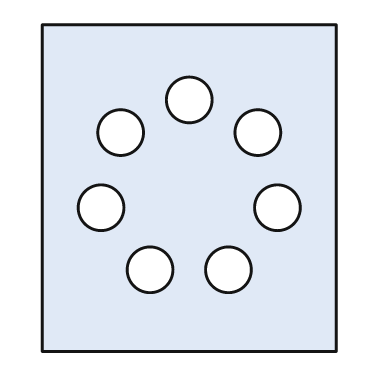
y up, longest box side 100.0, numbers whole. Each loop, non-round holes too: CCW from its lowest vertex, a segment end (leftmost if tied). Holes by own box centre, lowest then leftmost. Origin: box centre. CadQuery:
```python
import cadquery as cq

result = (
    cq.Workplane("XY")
    .moveTo(-45.0, -50.0)
    .lineTo(45.0, -50.0)
    .lineTo(45.0, 50.0)
    .lineTo(-45.0, 50.0)
    .close()
    .moveTo(-12.0, -25.0)
    .circle(7.0)
    .moveTo(12.0, -25.0)
    .circle(7.0)
    .moveTo(-27.0, -6.0)
    .circle(7.0)
    .moveTo(27.0, -6.0)
    .circle(7.0)
    .moveTo(-21.0, 17.0)
    .circle(7.0)
    .moveTo(21.0, 17.0)
    .circle(7.0)
    .moveTo(0.0, 27.0)
    .circle(7.0)
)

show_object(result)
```